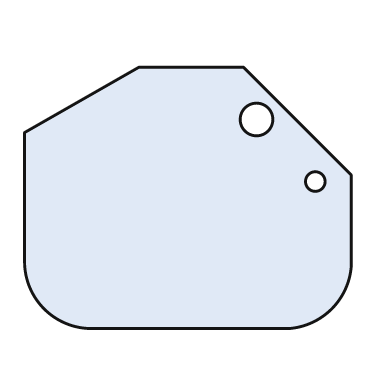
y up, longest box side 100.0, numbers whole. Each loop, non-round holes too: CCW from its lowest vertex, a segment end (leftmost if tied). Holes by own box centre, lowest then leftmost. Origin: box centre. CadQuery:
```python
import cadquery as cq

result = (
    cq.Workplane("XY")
    .moveTo(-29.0, -40.0)
    .lineTo(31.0, -40.0)
    .threePointArc((44.0, -34.0), (50.0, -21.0))
    .lineTo(50.0, 7.0)
    .lineTo(17.0, 40.0)
    .lineTo(-15.0, 40.0)
    .lineTo(-50.0, 20.0)
    .lineTo(-50.0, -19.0)
    .threePointArc((-44.0, -34.0), (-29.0, -40.0))
    .close()
    .moveTo(39.0, 5.0)
    .circle(3.0)
    .moveTo(21.0, 24.0)
    .circle(5.0)
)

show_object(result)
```